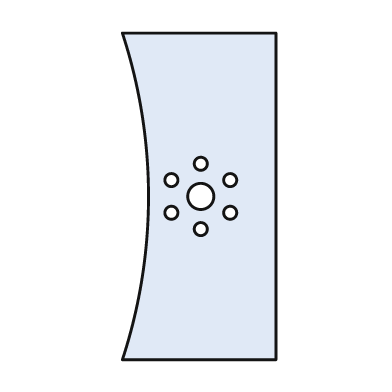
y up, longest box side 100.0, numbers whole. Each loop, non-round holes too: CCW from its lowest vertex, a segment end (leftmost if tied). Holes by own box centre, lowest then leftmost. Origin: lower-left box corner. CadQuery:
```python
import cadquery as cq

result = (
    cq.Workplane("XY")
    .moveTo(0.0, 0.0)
    .lineTo(47.0, 0.0)
    .lineTo(47.0, 100.0)
    .lineTo(0.0, 100.0)
    .threePointArc((8.0, 50.0), (0.0, 0.0))
    .close()
    .moveTo(24.0, 40.0)
    .circle(2.0)
    .moveTo(15.0, 45.0)
    .circle(2.0)
    .moveTo(33.0, 45.0)
    .circle(2.0)
    .moveTo(24.0, 50.0)
    .circle(4.0)
    .moveTo(15.0, 55.0)
    .circle(2.0)
    .moveTo(33.0, 55.0)
    .circle(2.0)
    .moveTo(24.0, 60.0)
    .circle(2.0)
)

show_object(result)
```